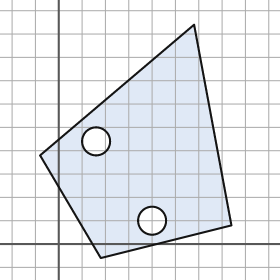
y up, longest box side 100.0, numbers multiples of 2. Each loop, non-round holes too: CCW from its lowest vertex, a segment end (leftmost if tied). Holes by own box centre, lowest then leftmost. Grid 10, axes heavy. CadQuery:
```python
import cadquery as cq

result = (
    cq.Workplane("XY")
    .moveTo(18.0, -6.0)
    .lineTo(74.0, 8.0)
    .lineTo(58.0, 94.0)
    .lineTo(-8.0, 38.0)
    .close()
    .moveTo(40.0, 10.0)
    .circle(6.0)
    .moveTo(16.0, 44.0)
    .circle(6.0)
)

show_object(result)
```